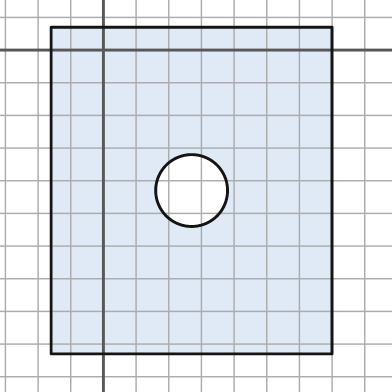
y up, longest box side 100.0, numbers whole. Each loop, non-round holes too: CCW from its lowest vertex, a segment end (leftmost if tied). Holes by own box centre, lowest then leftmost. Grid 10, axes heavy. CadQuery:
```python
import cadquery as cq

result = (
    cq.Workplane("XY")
    .moveTo(-16.0, -93.0)
    .lineTo(70.0, -93.0)
    .lineTo(70.0, 7.0)
    .lineTo(-16.0, 7.0)
    .close()
    .moveTo(27.0, -43.0)
    .circle(11.0)
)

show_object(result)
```